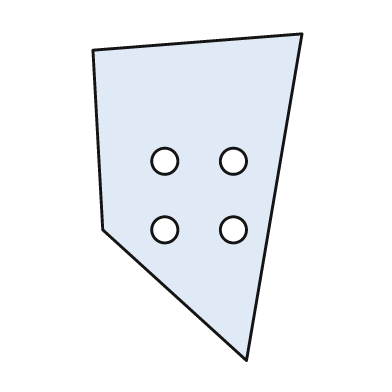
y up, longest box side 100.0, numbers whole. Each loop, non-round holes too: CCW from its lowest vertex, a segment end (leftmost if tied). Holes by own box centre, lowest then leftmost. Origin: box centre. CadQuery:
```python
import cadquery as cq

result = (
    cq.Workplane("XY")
    .moveTo(15.0, -50.0)
    .lineTo(32.0, 50.0)
    .lineTo(-32.0, 45.0)
    .lineTo(-29.0, -10.0)
    .close()
    .moveTo(-10.0, -10.0)
    .circle(4.0)
    .moveTo(11.0, -10.0)
    .circle(4.0)
    .moveTo(-10.0, 11.0)
    .circle(4.0)
    .moveTo(11.0, 11.0)
    .circle(4.0)
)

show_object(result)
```